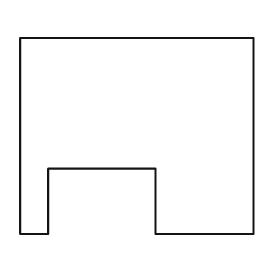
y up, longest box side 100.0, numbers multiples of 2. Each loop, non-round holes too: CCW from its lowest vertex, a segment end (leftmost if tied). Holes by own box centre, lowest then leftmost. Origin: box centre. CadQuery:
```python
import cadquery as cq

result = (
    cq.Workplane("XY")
    .moveTo(-50.0, -42.0)
    .lineTo(-38.0, -42.0)
    .lineTo(-38.0, -14.0)
    .lineTo(8.0, -14.0)
    .lineTo(8.0, -42.0)
    .lineTo(50.0, -42.0)
    .lineTo(50.0, 42.0)
    .lineTo(-50.0, 42.0)
    .close()
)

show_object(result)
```